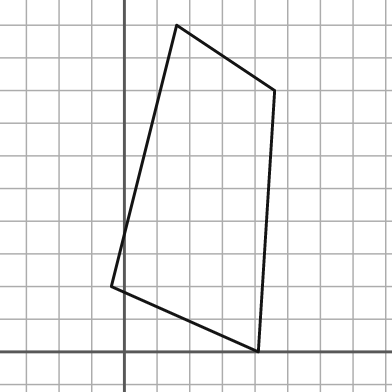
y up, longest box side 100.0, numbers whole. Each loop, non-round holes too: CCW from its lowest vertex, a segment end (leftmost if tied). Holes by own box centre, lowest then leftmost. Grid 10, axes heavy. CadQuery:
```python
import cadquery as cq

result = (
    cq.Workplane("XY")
    .moveTo(41.0, 0.0)
    .lineTo(46.0, 80.0)
    .lineTo(16.0, 100.0)
    .lineTo(-4.0, 20.0)
    .close()
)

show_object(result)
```